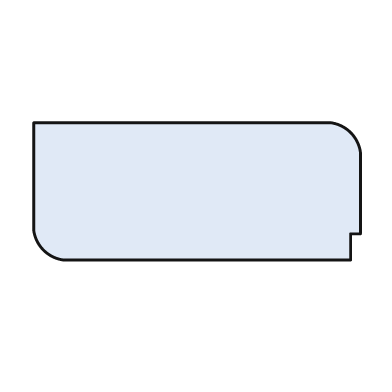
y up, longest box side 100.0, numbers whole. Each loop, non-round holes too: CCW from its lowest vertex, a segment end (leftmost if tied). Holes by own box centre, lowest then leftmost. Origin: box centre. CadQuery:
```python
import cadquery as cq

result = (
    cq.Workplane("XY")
    .moveTo(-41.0, -21.0)
    .lineTo(47.0, -21.0)
    .lineTo(47.0, -13.0)
    .lineTo(50.0, -13.0)
    .lineTo(50.0, 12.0)
    .threePointArc((47.0, 18.0), (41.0, 21.0))
    .lineTo(-50.0, 21.0)
    .lineTo(-50.0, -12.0)
    .threePointArc((-47.0, -18.0), (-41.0, -21.0))
    .close()
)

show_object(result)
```